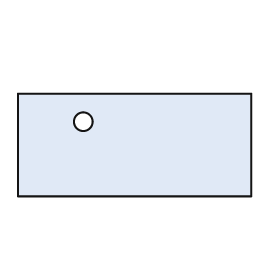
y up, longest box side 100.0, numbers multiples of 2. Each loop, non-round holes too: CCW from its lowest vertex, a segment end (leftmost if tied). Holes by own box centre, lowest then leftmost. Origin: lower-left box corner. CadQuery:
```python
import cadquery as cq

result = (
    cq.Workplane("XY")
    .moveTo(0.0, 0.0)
    .lineTo(100.0, 0.0)
    .lineTo(100.0, 44.0)
    .lineTo(0.0, 44.0)
    .close()
    .moveTo(28.0, 32.0)
    .circle(4.0)
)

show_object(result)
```